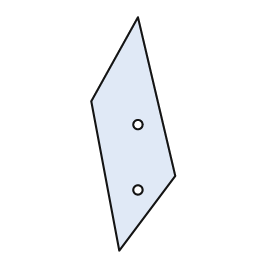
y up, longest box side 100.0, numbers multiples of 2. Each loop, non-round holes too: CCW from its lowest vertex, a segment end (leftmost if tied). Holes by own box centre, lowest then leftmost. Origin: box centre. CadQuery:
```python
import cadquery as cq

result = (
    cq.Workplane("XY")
    .moveTo(-6.0, -50.0)
    .lineTo(18.0, -18.0)
    .lineTo(2.0, 50.0)
    .lineTo(-18.0, 14.0)
    .close()
    .moveTo(2.0, -24.0)
    .circle(2.0)
    .moveTo(2.0, 4.0)
    .circle(2.0)
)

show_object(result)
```